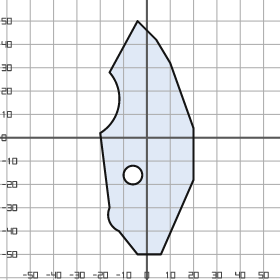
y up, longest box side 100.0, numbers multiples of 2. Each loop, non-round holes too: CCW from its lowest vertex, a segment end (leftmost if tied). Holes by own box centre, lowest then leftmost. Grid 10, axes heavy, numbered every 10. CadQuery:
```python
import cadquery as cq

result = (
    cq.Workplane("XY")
    .moveTo(-4.0, -50.0)
    .lineTo(6.0, -50.0)
    .lineTo(20.0, -18.0)
    .lineTo(20.0, 4.0)
    .lineTo(10.0, 32.0)
    .lineTo(4.0, 42.0)
    .lineTo(-4.0, 50.0)
    .lineTo(-16.0, 28.0)
    .threePointArc((-12.0, 14.0), (-20.0, 2.0))
    .lineTo(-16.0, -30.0)
    .threePointArc((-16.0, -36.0), (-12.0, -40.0))
    .close()
    .moveTo(-6.0, -16.0)
    .circle(4.0)
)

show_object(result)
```